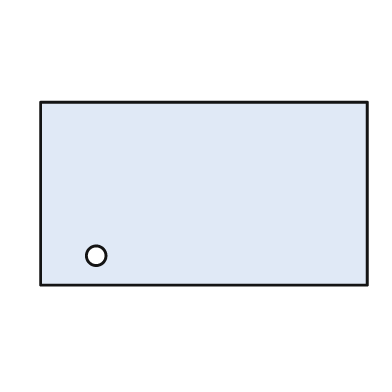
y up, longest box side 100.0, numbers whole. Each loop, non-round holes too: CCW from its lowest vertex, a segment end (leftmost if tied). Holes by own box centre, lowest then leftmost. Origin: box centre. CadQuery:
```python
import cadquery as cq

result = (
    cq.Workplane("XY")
    .moveTo(-50.0, -28.0)
    .lineTo(50.0, -28.0)
    .lineTo(50.0, 28.0)
    .lineTo(-50.0, 28.0)
    .close()
    .moveTo(-33.0, -19.0)
    .circle(3.0)
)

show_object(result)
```